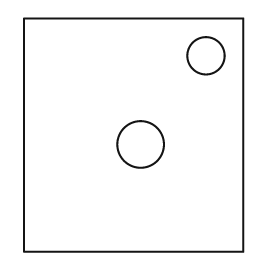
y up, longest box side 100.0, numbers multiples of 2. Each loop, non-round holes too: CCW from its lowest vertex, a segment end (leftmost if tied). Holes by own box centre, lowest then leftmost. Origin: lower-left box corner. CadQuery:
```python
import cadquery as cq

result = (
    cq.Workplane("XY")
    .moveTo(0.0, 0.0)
    .lineTo(94.0, 0.0)
    .lineTo(94.0, 100.0)
    .lineTo(0.0, 100.0)
    .close()
    .moveTo(50.0, 46.0)
    .circle(10.0)
    .moveTo(78.0, 84.0)
    .circle(8.0)
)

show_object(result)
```